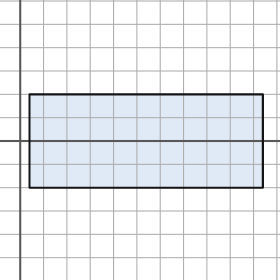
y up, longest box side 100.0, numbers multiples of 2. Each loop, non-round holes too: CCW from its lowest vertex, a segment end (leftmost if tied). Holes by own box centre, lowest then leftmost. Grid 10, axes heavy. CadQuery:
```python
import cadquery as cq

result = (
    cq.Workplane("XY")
    .moveTo(4.0, -20.0)
    .lineTo(104.0, -20.0)
    .lineTo(104.0, 20.0)
    .lineTo(4.0, 20.0)
    .close()
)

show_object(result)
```